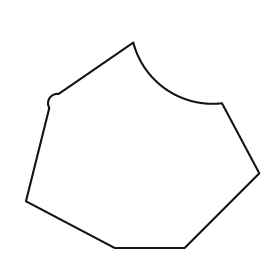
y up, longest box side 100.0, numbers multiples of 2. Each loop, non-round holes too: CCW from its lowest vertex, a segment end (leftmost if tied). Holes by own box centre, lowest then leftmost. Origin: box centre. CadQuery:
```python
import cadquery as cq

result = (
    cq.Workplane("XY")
    .moveTo(-12.0, -44.0)
    .lineTo(18.0, -44.0)
    .lineTo(50.0, -12.0)
    .lineTo(34.0, 18.0)
    .threePointArc((10.0, 24.0), (-4.0, 44.0))
    .lineTo(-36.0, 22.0)
    .threePointArc((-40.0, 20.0), (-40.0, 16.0))
    .lineTo(-50.0, -24.0)
    .close()
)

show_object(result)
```